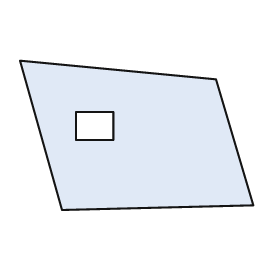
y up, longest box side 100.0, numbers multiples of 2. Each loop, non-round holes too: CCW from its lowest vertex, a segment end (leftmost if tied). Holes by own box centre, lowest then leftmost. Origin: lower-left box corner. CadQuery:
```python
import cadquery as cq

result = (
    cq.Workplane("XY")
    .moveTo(18.0, 0.0)
    .lineTo(100.0, 2.0)
    .lineTo(84.0, 56.0)
    .lineTo(0.0, 64.0)
    .close()
    .moveTo(24.0, 30.0)
    .lineTo(40.0, 30.0)
    .lineTo(40.0, 42.0)
    .lineTo(24.0, 42.0)
    .close()
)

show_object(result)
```